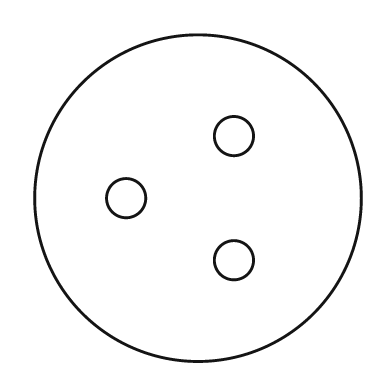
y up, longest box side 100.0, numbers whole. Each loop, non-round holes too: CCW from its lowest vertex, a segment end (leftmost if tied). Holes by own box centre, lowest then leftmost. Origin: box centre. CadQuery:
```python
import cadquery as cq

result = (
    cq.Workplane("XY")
    .moveTo(0.0, 0.0)
    .circle(50.0)
    .moveTo(11.0, -19.0)
    .circle(6.0)
    .moveTo(-22.0, 0.0)
    .circle(6.0)
    .moveTo(11.0, 19.0)
    .circle(6.0)
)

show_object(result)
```